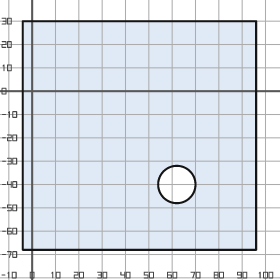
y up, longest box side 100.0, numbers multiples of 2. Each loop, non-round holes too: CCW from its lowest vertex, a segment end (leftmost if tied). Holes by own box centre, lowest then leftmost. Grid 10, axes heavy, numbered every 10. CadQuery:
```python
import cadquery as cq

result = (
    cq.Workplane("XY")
    .moveTo(-4.0, -68.0)
    .lineTo(96.0, -68.0)
    .lineTo(96.0, 30.0)
    .lineTo(-4.0, 30.0)
    .close()
    .moveTo(62.0, -40.0)
    .circle(8.0)
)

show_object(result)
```